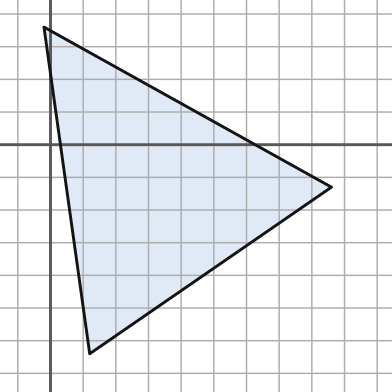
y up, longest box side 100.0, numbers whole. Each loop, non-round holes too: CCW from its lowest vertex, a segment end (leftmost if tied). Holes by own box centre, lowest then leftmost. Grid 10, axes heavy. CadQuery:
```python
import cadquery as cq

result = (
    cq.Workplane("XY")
    .moveTo(12.0, -64.0)
    .lineTo(86.0, -13.0)
    .lineTo(-2.0, 36.0)
    .close()
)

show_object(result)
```